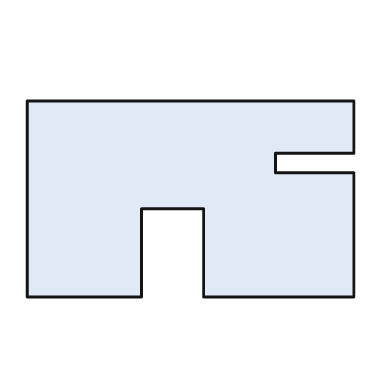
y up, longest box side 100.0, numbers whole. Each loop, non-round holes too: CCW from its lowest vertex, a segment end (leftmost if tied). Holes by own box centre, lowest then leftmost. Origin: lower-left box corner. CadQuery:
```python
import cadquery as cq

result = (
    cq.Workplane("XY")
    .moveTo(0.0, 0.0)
    .lineTo(35.0, 0.0)
    .lineTo(35.0, 27.0)
    .lineTo(54.0, 27.0)
    .lineTo(54.0, 0.0)
    .lineTo(100.0, 0.0)
    .lineTo(100.0, 38.0)
    .lineTo(76.0, 38.0)
    .lineTo(76.0, 44.0)
    .lineTo(100.0, 44.0)
    .lineTo(100.0, 60.0)
    .lineTo(0.0, 60.0)
    .close()
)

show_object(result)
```